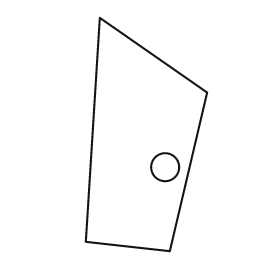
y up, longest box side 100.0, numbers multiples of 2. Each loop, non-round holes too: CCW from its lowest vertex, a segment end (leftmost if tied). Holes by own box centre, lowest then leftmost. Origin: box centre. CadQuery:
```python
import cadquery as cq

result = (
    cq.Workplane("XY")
    .moveTo(10.0, -50.0)
    .lineTo(26.0, 18.0)
    .lineTo(-20.0, 50.0)
    .lineTo(-26.0, -46.0)
    .close()
    .moveTo(8.0, -14.0)
    .circle(6.0)
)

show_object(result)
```